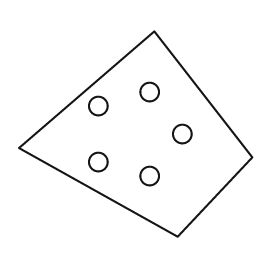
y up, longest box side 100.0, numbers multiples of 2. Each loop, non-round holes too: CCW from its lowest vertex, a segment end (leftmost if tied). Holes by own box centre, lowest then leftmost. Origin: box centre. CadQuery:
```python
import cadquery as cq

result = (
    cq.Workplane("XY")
    .moveTo(18.0, -44.0)
    .lineTo(50.0, -10.0)
    .lineTo(8.0, 44.0)
    .lineTo(-50.0, -6.0)
    .close()
    .moveTo(6.0, -18.0)
    .circle(4.0)
    .moveTo(-16.0, -12.0)
    .circle(4.0)
    .moveTo(20.0, 0.0)
    .circle(4.0)
    .moveTo(-16.0, 12.0)
    .circle(4.0)
    .moveTo(6.0, 18.0)
    .circle(4.0)
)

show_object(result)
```